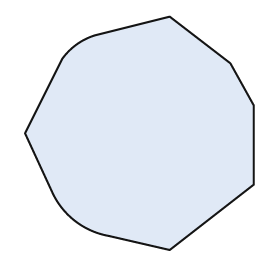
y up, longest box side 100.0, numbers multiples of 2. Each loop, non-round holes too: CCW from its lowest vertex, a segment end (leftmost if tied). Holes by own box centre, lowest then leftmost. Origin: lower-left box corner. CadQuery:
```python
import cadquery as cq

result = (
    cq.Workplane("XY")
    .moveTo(62.0, 0.0)
    .lineTo(98.0, 28.0)
    .lineTo(98.0, 62.0)
    .lineTo(88.0, 80.0)
    .lineTo(62.0, 100.0)
    .lineTo(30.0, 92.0)
    .threePointArc((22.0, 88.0), (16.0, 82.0))
    .lineTo(0.0, 50.0)
    .lineTo(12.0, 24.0)
    .threePointArc((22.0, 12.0), (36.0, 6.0))
    .close()
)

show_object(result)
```